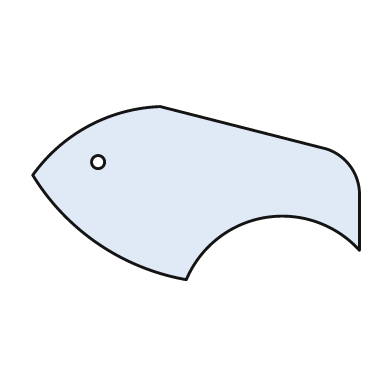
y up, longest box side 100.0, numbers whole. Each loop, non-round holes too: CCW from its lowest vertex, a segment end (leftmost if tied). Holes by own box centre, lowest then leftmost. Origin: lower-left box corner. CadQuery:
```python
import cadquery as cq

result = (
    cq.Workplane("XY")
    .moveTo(47.0, 0.0)
    .threePointArc((71.0, 19.0), (100.0, 9.0))
    .lineTo(100.0, 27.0)
    .threePointArc((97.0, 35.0), (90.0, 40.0))
    .lineTo(39.0, 53.0)
    .threePointArc((17.0, 47.0), (0.0, 32.0))
    .threePointArc((20.0, 11.0), (47.0, 0.0))
    .close()
    .moveTo(20.0, 36.0)
    .circle(2.0)
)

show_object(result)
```